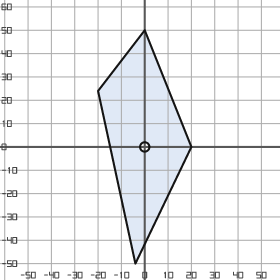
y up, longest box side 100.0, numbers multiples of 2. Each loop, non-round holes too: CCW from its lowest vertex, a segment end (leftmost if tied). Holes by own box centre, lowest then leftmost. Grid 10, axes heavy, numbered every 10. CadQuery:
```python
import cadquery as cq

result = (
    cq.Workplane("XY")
    .moveTo(-4.0, -50.0)
    .lineTo(20.0, 0.0)
    .lineTo(0.0, 50.0)
    .lineTo(-20.0, 24.0)
    .close()
    .moveTo(0.0, 0.0)
    .circle(2.0)
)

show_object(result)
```